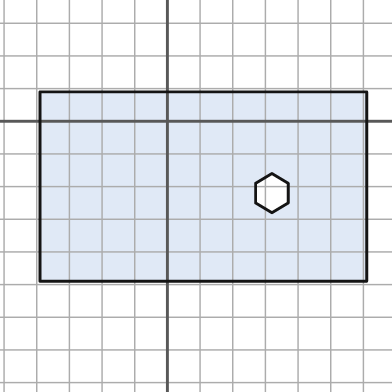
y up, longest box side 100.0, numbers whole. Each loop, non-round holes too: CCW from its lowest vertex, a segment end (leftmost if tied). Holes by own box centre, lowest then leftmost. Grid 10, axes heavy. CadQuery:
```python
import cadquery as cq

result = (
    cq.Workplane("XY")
    .moveTo(-39.0, -49.0)
    .lineTo(61.0, -49.0)
    .lineTo(61.0, 9.0)
    .lineTo(-39.0, 9.0)
    .close()
    .moveTo(32.0, -28.0)
    .lineTo(37.0, -25.0)
    .lineTo(37.0, -19.0)
    .lineTo(32.0, -16.0)
    .lineTo(27.0, -19.0)
    .lineTo(27.0, -25.0)
    .close()
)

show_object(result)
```